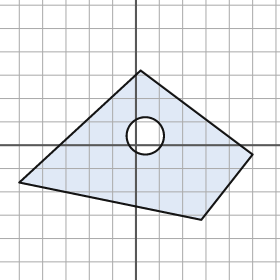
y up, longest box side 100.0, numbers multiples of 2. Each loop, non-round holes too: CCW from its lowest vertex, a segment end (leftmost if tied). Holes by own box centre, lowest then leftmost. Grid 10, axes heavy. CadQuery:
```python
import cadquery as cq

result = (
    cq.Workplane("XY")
    .moveTo(28.0, -32.0)
    .lineTo(50.0, -4.0)
    .lineTo(2.0, 32.0)
    .lineTo(-50.0, -16.0)
    .close()
    .moveTo(4.0, 4.0)
    .circle(8.0)
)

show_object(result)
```